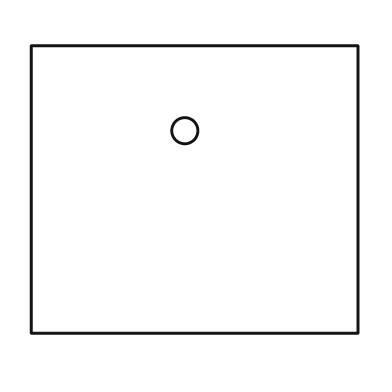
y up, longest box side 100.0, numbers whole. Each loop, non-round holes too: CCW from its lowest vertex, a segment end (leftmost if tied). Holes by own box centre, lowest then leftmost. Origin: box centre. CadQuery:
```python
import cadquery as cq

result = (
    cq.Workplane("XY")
    .moveTo(-50.0, -44.0)
    .lineTo(50.0, -44.0)
    .lineTo(50.0, 44.0)
    .lineTo(-50.0, 44.0)
    .close()
    .moveTo(-3.0, 18.0)
    .circle(4.0)
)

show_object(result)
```